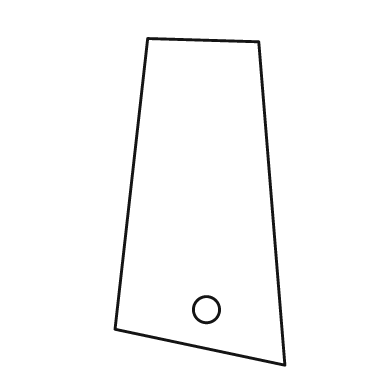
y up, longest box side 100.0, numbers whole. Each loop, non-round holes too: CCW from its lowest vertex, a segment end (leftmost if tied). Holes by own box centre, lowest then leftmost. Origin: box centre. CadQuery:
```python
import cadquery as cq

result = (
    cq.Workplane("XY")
    .moveTo(26.0, -50.0)
    .lineTo(18.0, 49.0)
    .lineTo(-16.0, 50.0)
    .lineTo(-26.0, -39.0)
    .close()
    .moveTo(2.0, -33.0)
    .circle(4.0)
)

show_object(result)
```